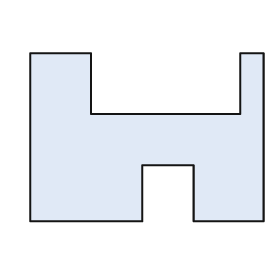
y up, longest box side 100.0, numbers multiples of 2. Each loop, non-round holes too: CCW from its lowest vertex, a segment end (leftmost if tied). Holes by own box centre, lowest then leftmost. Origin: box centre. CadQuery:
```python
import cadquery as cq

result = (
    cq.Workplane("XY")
    .moveTo(-50.0, -36.0)
    .lineTo(-2.0, -36.0)
    .lineTo(-2.0, -12.0)
    .lineTo(20.0, -12.0)
    .lineTo(20.0, -36.0)
    .lineTo(50.0, -36.0)
    .lineTo(50.0, 36.0)
    .lineTo(40.0, 36.0)
    .lineTo(40.0, 10.0)
    .lineTo(-24.0, 10.0)
    .lineTo(-24.0, 36.0)
    .lineTo(-50.0, 36.0)
    .close()
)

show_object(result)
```